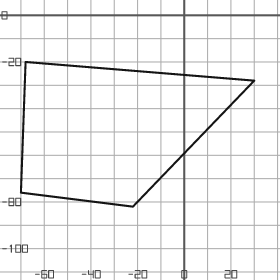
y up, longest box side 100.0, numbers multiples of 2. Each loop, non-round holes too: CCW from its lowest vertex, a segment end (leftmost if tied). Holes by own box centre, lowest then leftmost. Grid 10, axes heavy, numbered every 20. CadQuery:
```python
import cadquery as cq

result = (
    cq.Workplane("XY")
    .moveTo(-22.0, -82.0)
    .lineTo(30.0, -28.0)
    .lineTo(-68.0, -20.0)
    .lineTo(-70.0, -76.0)
    .close()
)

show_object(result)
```